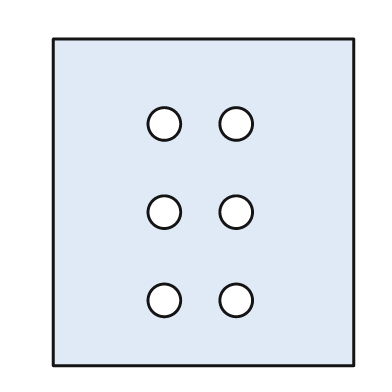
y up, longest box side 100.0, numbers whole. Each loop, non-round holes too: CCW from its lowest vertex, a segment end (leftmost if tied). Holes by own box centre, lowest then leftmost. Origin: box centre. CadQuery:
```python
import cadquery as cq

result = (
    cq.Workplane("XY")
    .moveTo(-46.0, -50.0)
    .lineTo(46.0, -50.0)
    .lineTo(46.0, 50.0)
    .lineTo(-46.0, 50.0)
    .close()
    .moveTo(-12.0, -30.0)
    .circle(5.0)
    .moveTo(10.0, -30.0)
    .circle(5.0)
    .moveTo(-12.0, -3.0)
    .circle(5.0)
    .moveTo(10.0, -3.0)
    .circle(5.0)
    .moveTo(-12.0, 24.0)
    .circle(5.0)
    .moveTo(10.0, 24.0)
    .circle(5.0)
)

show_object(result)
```